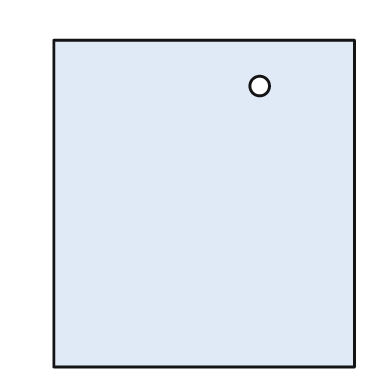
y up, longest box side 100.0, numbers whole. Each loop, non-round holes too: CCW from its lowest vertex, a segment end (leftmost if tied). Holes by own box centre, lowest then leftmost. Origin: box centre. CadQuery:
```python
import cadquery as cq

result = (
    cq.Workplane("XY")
    .moveTo(-46.0, -50.0)
    .lineTo(46.0, -50.0)
    .lineTo(46.0, 50.0)
    .lineTo(-46.0, 50.0)
    .close()
    .moveTo(17.0, 36.0)
    .circle(3.0)
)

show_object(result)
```